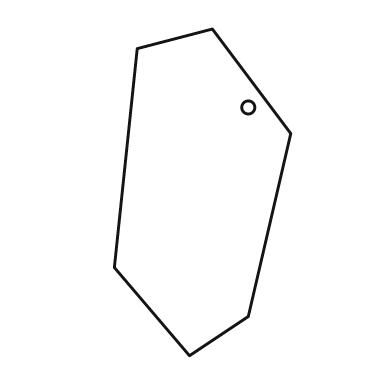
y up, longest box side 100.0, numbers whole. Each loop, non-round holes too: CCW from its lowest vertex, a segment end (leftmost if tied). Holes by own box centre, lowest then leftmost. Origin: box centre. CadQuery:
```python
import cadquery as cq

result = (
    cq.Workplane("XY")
    .moveTo(-4.0, -50.0)
    .lineTo(14.0, -38.0)
    .lineTo(27.0, 18.0)
    .lineTo(3.0, 50.0)
    .lineTo(-20.0, 44.0)
    .lineTo(-27.0, -23.0)
    .close()
    .moveTo(14.0, 26.0)
    .circle(2.0)
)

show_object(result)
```